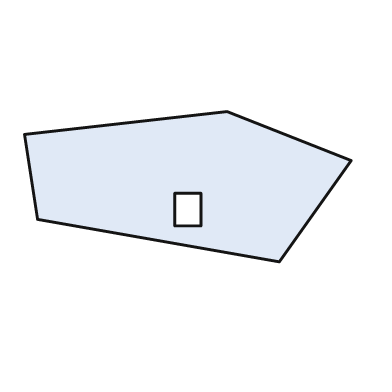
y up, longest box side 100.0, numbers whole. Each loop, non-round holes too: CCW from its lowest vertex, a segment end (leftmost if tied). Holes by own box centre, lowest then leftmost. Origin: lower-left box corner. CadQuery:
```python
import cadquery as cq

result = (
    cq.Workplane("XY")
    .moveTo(78.0, 0.0)
    .lineTo(100.0, 31.0)
    .lineTo(62.0, 46.0)
    .lineTo(0.0, 39.0)
    .lineTo(4.0, 13.0)
    .close()
    .moveTo(46.0, 11.0)
    .lineTo(54.0, 11.0)
    .lineTo(54.0, 21.0)
    .lineTo(46.0, 21.0)
    .close()
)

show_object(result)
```